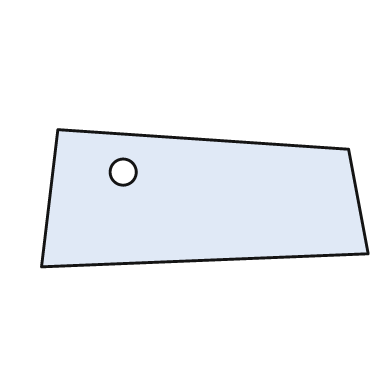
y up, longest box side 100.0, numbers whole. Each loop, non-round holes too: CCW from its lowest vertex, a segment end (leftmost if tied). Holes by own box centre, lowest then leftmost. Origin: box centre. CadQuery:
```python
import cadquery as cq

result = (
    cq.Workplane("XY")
    .moveTo(-50.0, -21.0)
    .lineTo(50.0, -17.0)
    .lineTo(44.0, 15.0)
    .lineTo(-45.0, 21.0)
    .close()
    .moveTo(-25.0, 8.0)
    .circle(4.0)
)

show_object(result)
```